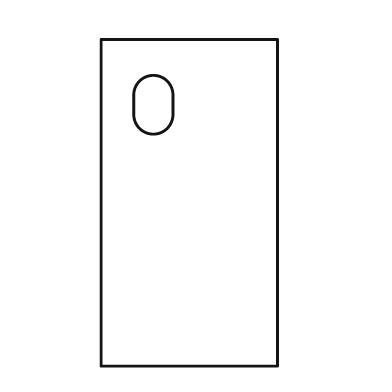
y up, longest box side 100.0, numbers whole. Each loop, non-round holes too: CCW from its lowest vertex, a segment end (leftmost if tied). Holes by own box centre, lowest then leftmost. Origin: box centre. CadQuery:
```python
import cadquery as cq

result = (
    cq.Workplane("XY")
    .moveTo(-27.0, -50.0)
    .lineTo(27.0, -50.0)
    .lineTo(27.0, 50.0)
    .lineTo(-27.0, 50.0)
    .close()
    .moveTo(-17.0, 27.0)
    .threePointArc((-11.0, 21.0), (-5.0, 27.0))
    .lineTo(-5.0, 33.0)
    .threePointArc((-11.0, 39.0), (-17.0, 33.0))
    .close()
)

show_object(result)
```